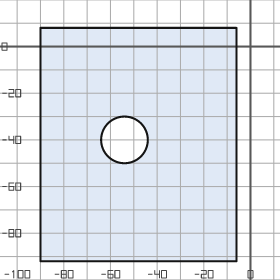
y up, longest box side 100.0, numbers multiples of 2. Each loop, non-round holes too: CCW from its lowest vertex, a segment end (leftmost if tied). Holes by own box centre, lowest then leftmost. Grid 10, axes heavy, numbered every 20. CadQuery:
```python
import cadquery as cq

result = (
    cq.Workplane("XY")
    .moveTo(-90.0, -92.0)
    .lineTo(-6.0, -92.0)
    .lineTo(-6.0, 8.0)
    .lineTo(-90.0, 8.0)
    .close()
    .moveTo(-54.0, -40.0)
    .circle(10.0)
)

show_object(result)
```